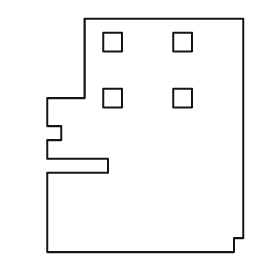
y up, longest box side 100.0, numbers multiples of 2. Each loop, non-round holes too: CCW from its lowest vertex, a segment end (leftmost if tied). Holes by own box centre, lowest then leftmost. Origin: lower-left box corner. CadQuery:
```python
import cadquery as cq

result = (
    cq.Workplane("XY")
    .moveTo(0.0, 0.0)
    .lineTo(80.0, 0.0)
    .lineTo(80.0, 6.0)
    .lineTo(84.0, 6.0)
    .lineTo(84.0, 100.0)
    .lineTo(16.0, 100.0)
    .lineTo(16.0, 66.0)
    .lineTo(0.0, 66.0)
    .lineTo(0.0, 54.0)
    .lineTo(6.0, 54.0)
    .lineTo(6.0, 48.0)
    .lineTo(0.0, 48.0)
    .lineTo(0.0, 40.0)
    .lineTo(26.0, 40.0)
    .lineTo(26.0, 34.0)
    .lineTo(0.0, 34.0)
    .close()
    .moveTo(24.0, 62.0)
    .lineTo(32.0, 62.0)
    .lineTo(32.0, 70.0)
    .lineTo(24.0, 70.0)
    .close()
    .moveTo(54.0, 62.0)
    .lineTo(62.0, 62.0)
    .lineTo(62.0, 70.0)
    .lineTo(54.0, 70.0)
    .close()
    .moveTo(24.0, 86.0)
    .lineTo(32.0, 86.0)
    .lineTo(32.0, 94.0)
    .lineTo(24.0, 94.0)
    .close()
    .moveTo(54.0, 86.0)
    .lineTo(62.0, 86.0)
    .lineTo(62.0, 94.0)
    .lineTo(54.0, 94.0)
    .close()
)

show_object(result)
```